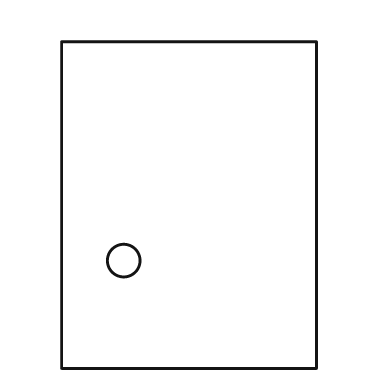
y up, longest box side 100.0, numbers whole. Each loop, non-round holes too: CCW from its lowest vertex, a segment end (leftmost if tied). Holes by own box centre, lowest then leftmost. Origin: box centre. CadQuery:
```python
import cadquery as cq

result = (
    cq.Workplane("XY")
    .moveTo(-39.0, -50.0)
    .lineTo(39.0, -50.0)
    .lineTo(39.0, 50.0)
    .lineTo(-39.0, 50.0)
    .close()
    .moveTo(-20.0, -17.0)
    .circle(5.0)
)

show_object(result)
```